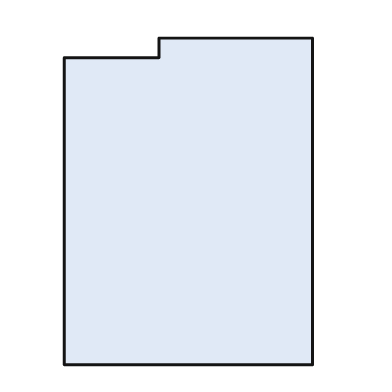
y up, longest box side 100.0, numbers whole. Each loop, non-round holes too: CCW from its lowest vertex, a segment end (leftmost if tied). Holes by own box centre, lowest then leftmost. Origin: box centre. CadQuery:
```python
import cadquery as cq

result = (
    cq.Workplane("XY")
    .moveTo(-38.0, -50.0)
    .lineTo(38.0, -50.0)
    .lineTo(38.0, 50.0)
    .lineTo(-9.0, 50.0)
    .lineTo(-9.0, 44.0)
    .lineTo(-38.0, 44.0)
    .close()
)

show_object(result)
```